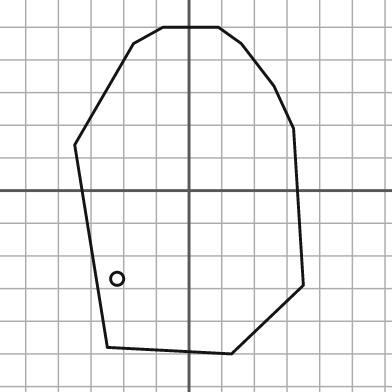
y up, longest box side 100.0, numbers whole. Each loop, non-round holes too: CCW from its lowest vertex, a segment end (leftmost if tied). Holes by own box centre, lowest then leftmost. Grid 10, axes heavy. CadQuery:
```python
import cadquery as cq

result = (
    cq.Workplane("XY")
    .moveTo(13.0, -50.0)
    .lineTo(35.0, -29.0)
    .lineTo(32.0, 19.0)
    .lineTo(26.0, 32.0)
    .lineTo(16.0, 45.0)
    .lineTo(9.0, 50.0)
    .lineTo(-8.0, 50.0)
    .lineTo(-17.0, 45.0)
    .lineTo(-35.0, 14.0)
    .lineTo(-25.0, -48.0)
    .close()
    .moveTo(-22.0, -27.0)
    .circle(2.0)
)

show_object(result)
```